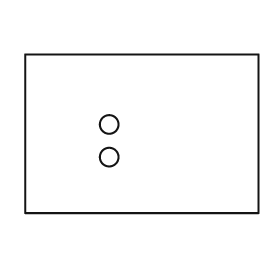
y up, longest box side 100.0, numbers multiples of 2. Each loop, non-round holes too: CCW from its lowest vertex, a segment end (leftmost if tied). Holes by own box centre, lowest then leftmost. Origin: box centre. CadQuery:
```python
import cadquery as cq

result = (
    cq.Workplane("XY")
    .moveTo(-50.0, -34.0)
    .lineTo(50.0, -34.0)
    .lineTo(50.0, 34.0)
    .lineTo(-50.0, 34.0)
    .close()
    .moveTo(-14.0, -10.0)
    .circle(4.0)
    .moveTo(-14.0, 4.0)
    .circle(4.0)
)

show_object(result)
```